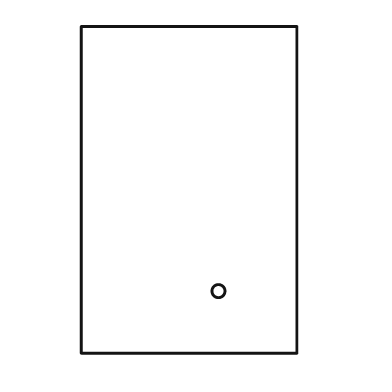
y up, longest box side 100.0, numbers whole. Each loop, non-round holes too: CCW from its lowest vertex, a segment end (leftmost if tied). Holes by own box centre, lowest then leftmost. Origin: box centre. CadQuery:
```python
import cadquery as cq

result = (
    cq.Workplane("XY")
    .moveTo(-33.0, -50.0)
    .lineTo(33.0, -50.0)
    .lineTo(33.0, 50.0)
    .lineTo(-33.0, 50.0)
    .close()
    .moveTo(9.0, -31.0)
    .circle(2.0)
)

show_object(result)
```